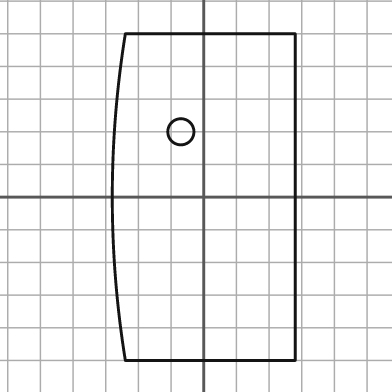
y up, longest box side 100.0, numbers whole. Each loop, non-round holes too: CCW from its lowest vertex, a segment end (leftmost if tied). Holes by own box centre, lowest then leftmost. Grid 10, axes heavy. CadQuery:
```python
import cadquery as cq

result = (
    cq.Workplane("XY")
    .moveTo(-24.0, -50.0)
    .lineTo(28.0, -50.0)
    .lineTo(28.0, 50.0)
    .lineTo(-24.0, 50.0)
    .threePointArc((-28.0, 0.0), (-24.0, -50.0))
    .close()
    .moveTo(-7.0, 20.0)
    .circle(4.0)
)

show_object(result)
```